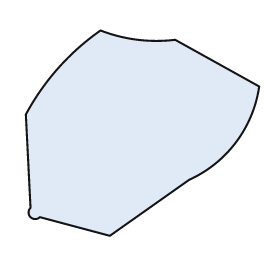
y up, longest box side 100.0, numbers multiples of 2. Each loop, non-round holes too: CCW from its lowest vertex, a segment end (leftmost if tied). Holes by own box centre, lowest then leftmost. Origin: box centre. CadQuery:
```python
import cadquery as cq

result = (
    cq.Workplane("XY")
    .moveTo(-14.0, -44.0)
    .lineTo(20.0, -20.0)
    .threePointArc((40.0, -4.0), (50.0, 20.0))
    .lineTo(14.0, 40.0)
    .threePointArc((-2.0, 40.0), (-18.0, 44.0))
    .threePointArc((-36.0, 28.0), (-50.0, 8.0))
    .lineTo(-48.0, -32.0)
    .threePointArc((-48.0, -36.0), (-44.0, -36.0))
    .close()
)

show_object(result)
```